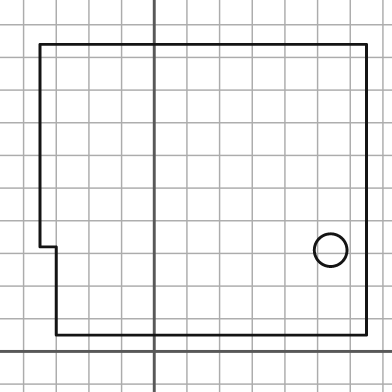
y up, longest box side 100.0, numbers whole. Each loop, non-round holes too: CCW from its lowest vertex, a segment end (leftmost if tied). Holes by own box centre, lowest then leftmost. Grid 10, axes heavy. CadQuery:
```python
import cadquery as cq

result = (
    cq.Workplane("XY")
    .moveTo(-30.0, 5.0)
    .lineTo(65.0, 5.0)
    .lineTo(65.0, 94.0)
    .lineTo(-35.0, 94.0)
    .lineTo(-35.0, 32.0)
    .lineTo(-30.0, 32.0)
    .close()
    .moveTo(54.0, 31.0)
    .circle(5.0)
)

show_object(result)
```